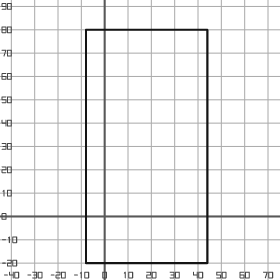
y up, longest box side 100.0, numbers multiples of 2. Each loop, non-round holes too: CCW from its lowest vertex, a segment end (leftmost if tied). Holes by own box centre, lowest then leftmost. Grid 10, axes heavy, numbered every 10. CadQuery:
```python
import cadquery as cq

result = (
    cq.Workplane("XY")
    .moveTo(-8.0, -20.0)
    .lineTo(44.0, -20.0)
    .lineTo(44.0, 80.0)
    .lineTo(-8.0, 80.0)
    .close()
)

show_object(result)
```